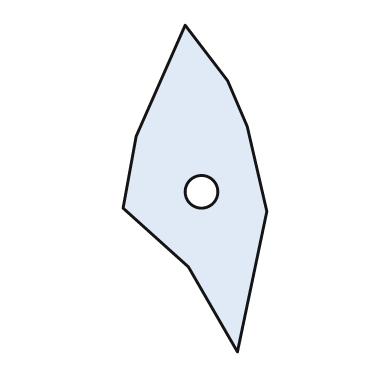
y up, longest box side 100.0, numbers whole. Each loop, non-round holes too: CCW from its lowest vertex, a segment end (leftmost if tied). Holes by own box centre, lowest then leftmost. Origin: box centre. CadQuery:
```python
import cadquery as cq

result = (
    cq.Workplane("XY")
    .moveTo(13.0, -50.0)
    .lineTo(22.0, -7.0)
    .lineTo(16.0, 19.0)
    .lineTo(10.0, 33.0)
    .lineTo(-3.0, 50.0)
    .lineTo(-18.0, 16.0)
    .lineTo(-22.0, -6.0)
    .lineTo(-2.0, -24.0)
    .close()
    .moveTo(2.0, -1.0)
    .circle(5.0)
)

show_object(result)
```